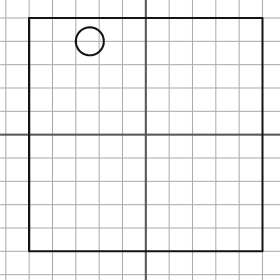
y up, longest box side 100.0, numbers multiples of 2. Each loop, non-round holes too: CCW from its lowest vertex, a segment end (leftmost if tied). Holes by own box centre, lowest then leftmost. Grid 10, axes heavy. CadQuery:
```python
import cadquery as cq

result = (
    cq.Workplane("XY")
    .moveTo(-50.0, -50.0)
    .lineTo(50.0, -50.0)
    .lineTo(50.0, 50.0)
    .lineTo(-50.0, 50.0)
    .close()
    .moveTo(-24.0, 40.0)
    .circle(6.0)
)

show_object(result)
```